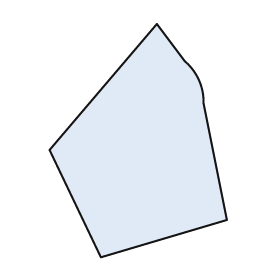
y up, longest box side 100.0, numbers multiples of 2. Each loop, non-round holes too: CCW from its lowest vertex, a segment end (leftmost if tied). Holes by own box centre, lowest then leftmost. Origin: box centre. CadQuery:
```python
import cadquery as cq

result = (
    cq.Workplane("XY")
    .moveTo(-16.0, -50.0)
    .lineTo(38.0, -34.0)
    .lineTo(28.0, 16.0)
    .threePointArc((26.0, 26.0), (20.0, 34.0))
    .lineTo(8.0, 50.0)
    .lineTo(-38.0, -4.0)
    .close()
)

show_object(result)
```